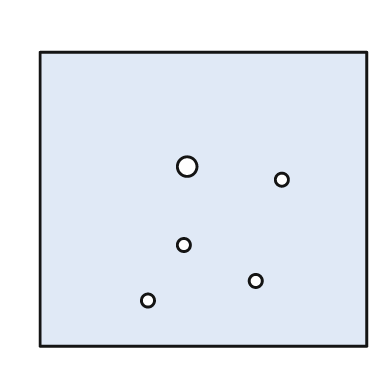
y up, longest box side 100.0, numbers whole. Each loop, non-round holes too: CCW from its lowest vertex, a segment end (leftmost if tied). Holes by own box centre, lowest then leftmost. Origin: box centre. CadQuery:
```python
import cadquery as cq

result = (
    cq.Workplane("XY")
    .moveTo(-50.0, -45.0)
    .lineTo(50.0, -45.0)
    .lineTo(50.0, 45.0)
    .lineTo(-50.0, 45.0)
    .close()
    .moveTo(-17.0, -31.0)
    .circle(2.0)
    .moveTo(16.0, -25.0)
    .circle(2.0)
    .moveTo(-6.0, -14.0)
    .circle(2.0)
    .moveTo(24.0, 6.0)
    .circle(2.0)
    .moveTo(-5.0, 10.0)
    .circle(3.0)
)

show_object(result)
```